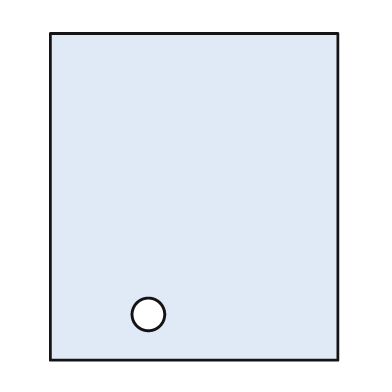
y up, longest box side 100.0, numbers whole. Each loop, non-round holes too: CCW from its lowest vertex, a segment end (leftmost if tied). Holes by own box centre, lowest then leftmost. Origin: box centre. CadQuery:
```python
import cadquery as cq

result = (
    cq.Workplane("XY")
    .moveTo(-44.0, -50.0)
    .lineTo(44.0, -50.0)
    .lineTo(44.0, 50.0)
    .lineTo(-44.0, 50.0)
    .close()
    .moveTo(-14.0, -36.0)
    .circle(5.0)
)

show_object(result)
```